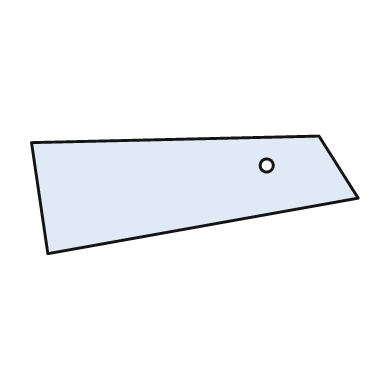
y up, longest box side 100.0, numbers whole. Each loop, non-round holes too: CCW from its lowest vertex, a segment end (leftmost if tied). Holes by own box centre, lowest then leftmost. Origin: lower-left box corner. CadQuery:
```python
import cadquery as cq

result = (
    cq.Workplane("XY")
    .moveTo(5.0, 0.0)
    .lineTo(100.0, 17.0)
    .lineTo(88.0, 36.0)
    .lineTo(0.0, 34.0)
    .close()
    .moveTo(72.0, 27.0)
    .circle(2.0)
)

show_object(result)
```